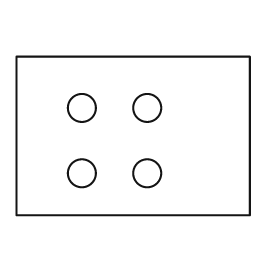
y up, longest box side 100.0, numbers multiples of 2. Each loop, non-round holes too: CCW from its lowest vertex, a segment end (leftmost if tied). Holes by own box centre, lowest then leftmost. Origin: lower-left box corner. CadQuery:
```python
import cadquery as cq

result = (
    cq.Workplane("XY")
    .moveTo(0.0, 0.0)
    .lineTo(100.0, 0.0)
    .lineTo(100.0, 68.0)
    .lineTo(0.0, 68.0)
    .close()
    .moveTo(28.0, 18.0)
    .circle(6.0)
    .moveTo(56.0, 18.0)
    .circle(6.0)
    .moveTo(28.0, 46.0)
    .circle(6.0)
    .moveTo(56.0, 46.0)
    .circle(6.0)
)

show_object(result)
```